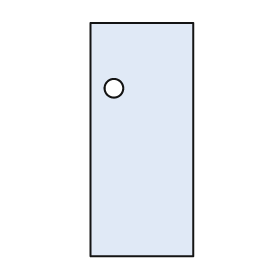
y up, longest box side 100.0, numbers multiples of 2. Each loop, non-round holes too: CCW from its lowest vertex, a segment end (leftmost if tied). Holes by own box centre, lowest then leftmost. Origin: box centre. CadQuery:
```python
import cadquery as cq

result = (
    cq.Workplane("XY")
    .moveTo(-22.0, -50.0)
    .lineTo(22.0, -50.0)
    .lineTo(22.0, 50.0)
    .lineTo(-22.0, 50.0)
    .close()
    .moveTo(-12.0, 22.0)
    .circle(4.0)
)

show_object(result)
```